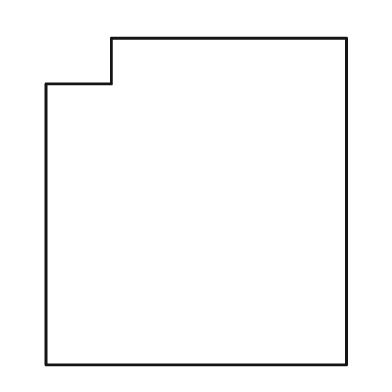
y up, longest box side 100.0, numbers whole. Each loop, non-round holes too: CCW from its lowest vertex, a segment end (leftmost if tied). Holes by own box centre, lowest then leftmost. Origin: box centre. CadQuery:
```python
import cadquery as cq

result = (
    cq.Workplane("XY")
    .moveTo(-46.0, -50.0)
    .lineTo(46.0, -50.0)
    .lineTo(46.0, 50.0)
    .lineTo(-26.0, 50.0)
    .lineTo(-26.0, 36.0)
    .lineTo(-46.0, 36.0)
    .close()
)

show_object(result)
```